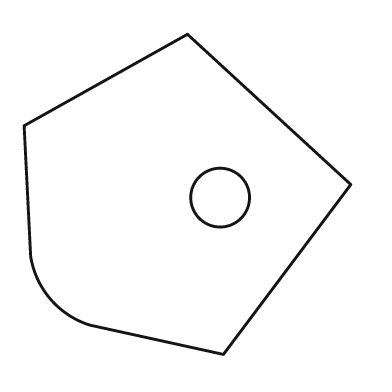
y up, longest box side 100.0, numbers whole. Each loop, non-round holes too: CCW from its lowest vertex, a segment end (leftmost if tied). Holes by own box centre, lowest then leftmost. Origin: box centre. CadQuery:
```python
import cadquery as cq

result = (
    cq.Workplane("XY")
    .moveTo(11.0, -49.0)
    .lineTo(50.0, 3.0)
    .lineTo(0.0, 49.0)
    .lineTo(-50.0, 21.0)
    .lineTo(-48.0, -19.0)
    .threePointArc((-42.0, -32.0), (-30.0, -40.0))
    .close()
    .moveTo(10.0, -1.0)
    .circle(9.0)
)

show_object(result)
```